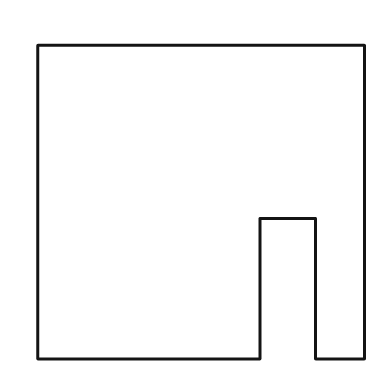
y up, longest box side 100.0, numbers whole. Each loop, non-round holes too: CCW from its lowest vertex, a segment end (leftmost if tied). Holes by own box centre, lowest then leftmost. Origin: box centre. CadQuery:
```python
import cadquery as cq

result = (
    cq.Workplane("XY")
    .moveTo(-50.0, -48.0)
    .lineTo(18.0, -48.0)
    .lineTo(18.0, -5.0)
    .lineTo(35.0, -5.0)
    .lineTo(35.0, -48.0)
    .lineTo(50.0, -48.0)
    .lineTo(50.0, 48.0)
    .lineTo(-50.0, 48.0)
    .close()
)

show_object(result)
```